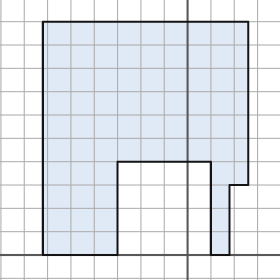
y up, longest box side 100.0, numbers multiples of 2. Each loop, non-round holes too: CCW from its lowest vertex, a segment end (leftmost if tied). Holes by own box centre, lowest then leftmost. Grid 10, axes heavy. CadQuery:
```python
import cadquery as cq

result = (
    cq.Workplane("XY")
    .moveTo(-62.0, 0.0)
    .lineTo(-30.0, 0.0)
    .lineTo(-30.0, 40.0)
    .lineTo(10.0, 40.0)
    .lineTo(10.0, 0.0)
    .lineTo(18.0, 0.0)
    .lineTo(18.0, 30.0)
    .lineTo(26.0, 30.0)
    .lineTo(26.0, 100.0)
    .lineTo(-62.0, 100.0)
    .close()
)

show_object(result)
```